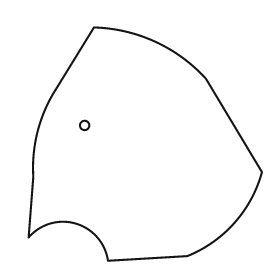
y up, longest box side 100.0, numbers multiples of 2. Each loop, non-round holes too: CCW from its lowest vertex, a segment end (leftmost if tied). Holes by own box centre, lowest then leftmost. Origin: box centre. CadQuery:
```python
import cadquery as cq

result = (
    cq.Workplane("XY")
    .moveTo(-16.0, -50.0)
    .lineTo(18.0, -48.0)
    .threePointArc((38.0, -34.0), (50.0, -12.0))
    .lineTo(26.0, 28.0)
    .threePointArc((4.0, 44.0), (-22.0, 50.0))
    .lineTo(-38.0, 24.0)
    .threePointArc((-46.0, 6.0), (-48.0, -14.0))
    .lineTo(-50.0, -40.0)
    .threePointArc((-30.0, -34.0), (-16.0, -50.0))
    .close()
    .moveTo(-26.0, 8.0)
    .circle(2.0)
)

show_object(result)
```